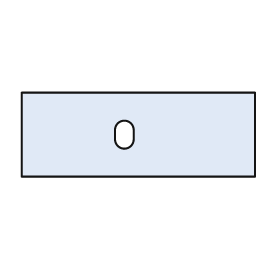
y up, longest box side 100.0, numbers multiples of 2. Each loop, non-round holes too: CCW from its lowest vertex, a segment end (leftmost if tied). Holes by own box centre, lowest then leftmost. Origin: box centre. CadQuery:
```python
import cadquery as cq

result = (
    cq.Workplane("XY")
    .moveTo(-50.0, -18.0)
    .lineTo(50.0, -18.0)
    .lineTo(50.0, 18.0)
    .lineTo(-50.0, 18.0)
    .close()
    .moveTo(-10.0, -2.0)
    .threePointArc((-6.0, -6.0), (-2.0, -2.0))
    .lineTo(-2.0, 2.0)
    .threePointArc((-6.0, 6.0), (-10.0, 2.0))
    .close()
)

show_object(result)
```